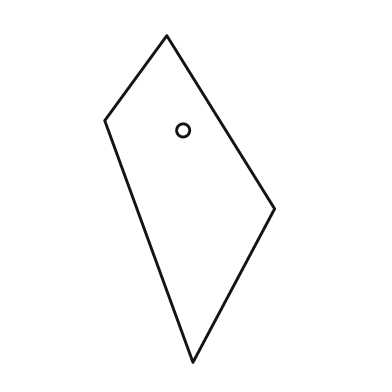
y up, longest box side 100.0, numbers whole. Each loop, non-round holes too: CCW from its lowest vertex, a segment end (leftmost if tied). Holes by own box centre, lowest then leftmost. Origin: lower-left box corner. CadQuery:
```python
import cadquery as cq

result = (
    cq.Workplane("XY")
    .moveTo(27.0, 0.0)
    .lineTo(52.0, 47.0)
    .lineTo(19.0, 100.0)
    .lineTo(0.0, 74.0)
    .close()
    .moveTo(24.0, 71.0)
    .circle(2.0)
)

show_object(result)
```